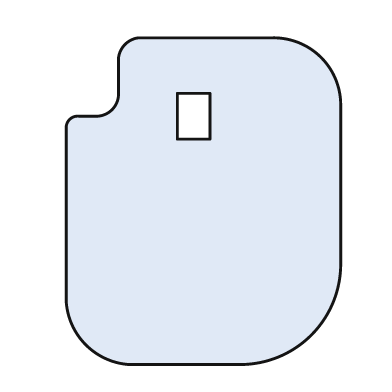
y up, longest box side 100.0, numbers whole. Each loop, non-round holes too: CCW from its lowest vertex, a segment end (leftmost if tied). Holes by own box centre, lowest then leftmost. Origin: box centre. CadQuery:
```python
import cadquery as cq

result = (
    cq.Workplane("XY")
    .moveTo(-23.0, -50.0)
    .lineTo(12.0, -50.0)
    .threePointArc((33.0, -41.0), (42.0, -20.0))
    .lineTo(42.0, 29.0)
    .threePointArc((36.0, 44.0), (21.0, 50.0))
    .lineTo(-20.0, 50.0)
    .threePointArc((-24.0, 48.0), (-26.0, 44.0))
    .lineTo(-26.0, 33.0)
    .threePointArc((-28.0, 28.0), (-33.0, 26.0))
    .lineTo(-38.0, 26.0)
    .threePointArc((-41.0, 25.0), (-42.0, 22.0))
    .lineTo(-42.0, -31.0)
    .threePointArc((-36.0, -44.0), (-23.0, -50.0))
    .close()
    .moveTo(-8.0, 19.0)
    .lineTo(2.0, 19.0)
    .lineTo(2.0, 33.0)
    .lineTo(-8.0, 33.0)
    .close()
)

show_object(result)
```